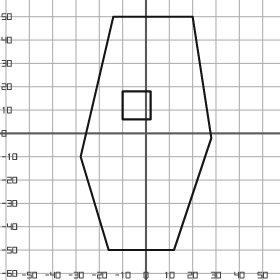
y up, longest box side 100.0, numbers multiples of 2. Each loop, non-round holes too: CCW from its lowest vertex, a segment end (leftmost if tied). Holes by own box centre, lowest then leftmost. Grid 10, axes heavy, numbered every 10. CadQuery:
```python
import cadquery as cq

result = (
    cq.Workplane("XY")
    .moveTo(-16.0, -50.0)
    .lineTo(12.0, -50.0)
    .lineTo(28.0, -2.0)
    .lineTo(20.0, 50.0)
    .lineTo(-14.0, 50.0)
    .lineTo(-28.0, -10.0)
    .close()
    .moveTo(-10.0, 6.0)
    .lineTo(2.0, 6.0)
    .lineTo(2.0, 18.0)
    .lineTo(-10.0, 18.0)
    .close()
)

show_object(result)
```